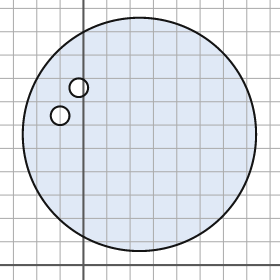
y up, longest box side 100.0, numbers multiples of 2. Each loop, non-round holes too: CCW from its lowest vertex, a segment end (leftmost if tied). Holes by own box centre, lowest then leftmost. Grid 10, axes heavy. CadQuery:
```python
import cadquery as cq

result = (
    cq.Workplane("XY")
    .moveTo(24.0, 56.0)
    .circle(50.0)
    .moveTo(-10.0, 64.0)
    .circle(4.0)
    .moveTo(-2.0, 76.0)
    .circle(4.0)
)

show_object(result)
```